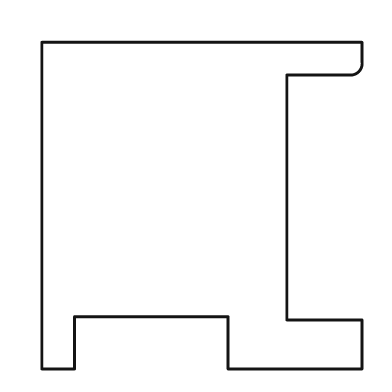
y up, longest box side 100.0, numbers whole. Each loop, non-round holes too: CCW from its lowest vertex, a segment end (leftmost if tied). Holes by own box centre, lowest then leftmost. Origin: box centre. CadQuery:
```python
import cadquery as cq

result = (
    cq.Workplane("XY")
    .moveTo(-49.0, -50.0)
    .lineTo(-39.0, -50.0)
    .lineTo(-39.0, -34.0)
    .lineTo(8.0, -34.0)
    .lineTo(8.0, -50.0)
    .lineTo(49.0, -50.0)
    .lineTo(49.0, -35.0)
    .lineTo(26.0, -35.0)
    .lineTo(26.0, 40.0)
    .lineTo(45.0, 40.0)
    .threePointArc((48.0, 41.0), (49.0, 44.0))
    .lineTo(49.0, 50.0)
    .lineTo(-49.0, 50.0)
    .close()
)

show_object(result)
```